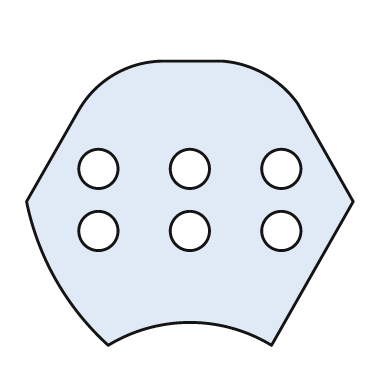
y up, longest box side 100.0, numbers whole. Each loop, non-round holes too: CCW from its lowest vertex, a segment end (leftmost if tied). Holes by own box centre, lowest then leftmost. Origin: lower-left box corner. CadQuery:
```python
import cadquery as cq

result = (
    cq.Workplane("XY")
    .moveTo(25.0, 0.0)
    .threePointArc((50.0, 7.0), (75.0, 0.0))
    .lineTo(100.0, 44.0)
    .lineTo(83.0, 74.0)
    .threePointArc((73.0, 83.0), (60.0, 87.0))
    .lineTo(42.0, 87.0)
    .threePointArc((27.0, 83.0), (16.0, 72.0))
    .lineTo(0.0, 44.0)
    .threePointArc((9.0, 20.0), (25.0, 0.0))
    .close()
    .moveTo(22.0, 35.0)
    .circle(6.0)
    .moveTo(50.0, 35.0)
    .circle(6.0)
    .moveTo(78.0, 35.0)
    .circle(6.0)
    .moveTo(22.0, 54.0)
    .circle(6.0)
    .moveTo(50.0, 54.0)
    .circle(6.0)
    .moveTo(78.0, 54.0)
    .circle(6.0)
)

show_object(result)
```